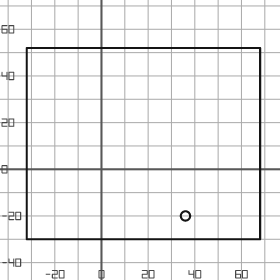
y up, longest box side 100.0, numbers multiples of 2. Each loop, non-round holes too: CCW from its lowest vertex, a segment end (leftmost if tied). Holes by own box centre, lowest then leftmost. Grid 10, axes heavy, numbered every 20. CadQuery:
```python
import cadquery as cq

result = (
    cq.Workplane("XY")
    .moveTo(-32.0, -30.0)
    .lineTo(68.0, -30.0)
    .lineTo(68.0, 52.0)
    .lineTo(-32.0, 52.0)
    .close()
    .moveTo(36.0, -20.0)
    .circle(2.0)
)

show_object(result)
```